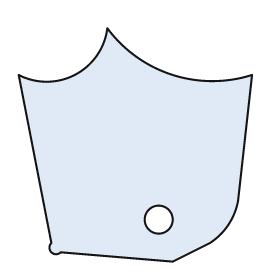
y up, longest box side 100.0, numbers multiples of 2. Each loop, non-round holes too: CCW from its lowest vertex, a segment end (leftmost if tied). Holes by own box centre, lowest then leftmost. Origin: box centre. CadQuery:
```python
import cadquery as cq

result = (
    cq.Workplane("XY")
    .moveTo(16.0, -50.0)
    .lineTo(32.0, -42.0)
    .threePointArc((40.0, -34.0), (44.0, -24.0))
    .lineTo(50.0, 30.0)
    .threePointArc((16.0, 30.0), (-12.0, 50.0))
    .threePointArc((-26.0, 30.0), (-50.0, 30.0))
    .lineTo(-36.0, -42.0)
    .threePointArc((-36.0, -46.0), (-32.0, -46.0))
    .close()
    .moveTo(10.0, -32.0)
    .circle(6.0)
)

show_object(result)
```